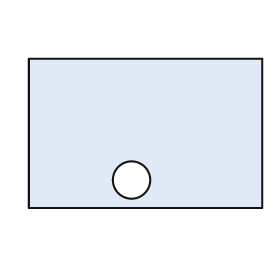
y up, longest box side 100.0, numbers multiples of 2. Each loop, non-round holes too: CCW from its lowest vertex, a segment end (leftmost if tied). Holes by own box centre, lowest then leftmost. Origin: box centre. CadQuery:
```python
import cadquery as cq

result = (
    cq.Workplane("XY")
    .moveTo(-50.0, -32.0)
    .lineTo(50.0, -32.0)
    .lineTo(50.0, 32.0)
    .lineTo(-50.0, 32.0)
    .close()
    .moveTo(-6.0, -20.0)
    .circle(8.0)
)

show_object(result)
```